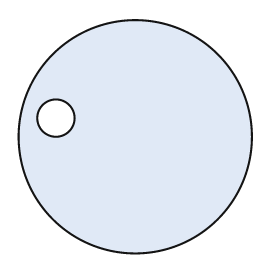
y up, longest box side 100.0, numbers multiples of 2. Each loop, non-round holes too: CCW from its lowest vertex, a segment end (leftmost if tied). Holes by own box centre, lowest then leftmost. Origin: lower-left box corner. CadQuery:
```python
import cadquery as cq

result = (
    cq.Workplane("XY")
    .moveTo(50.0, 50.0)
    .circle(50.0)
    .moveTo(16.0, 58.0)
    .circle(8.0)
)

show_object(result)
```